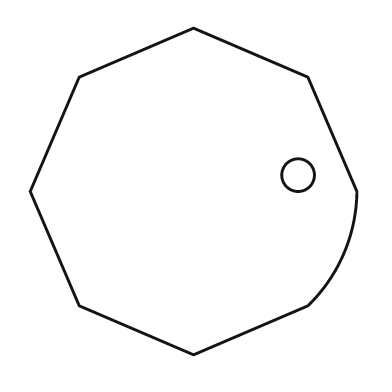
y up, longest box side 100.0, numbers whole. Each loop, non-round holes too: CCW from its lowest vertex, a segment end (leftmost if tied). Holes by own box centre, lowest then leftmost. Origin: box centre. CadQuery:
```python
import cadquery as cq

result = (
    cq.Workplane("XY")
    .moveTo(0.0, -50.0)
    .lineTo(35.0, -35.0)
    .threePointArc((46.0, -19.0), (50.0, 0.0))
    .lineTo(35.0, 35.0)
    .lineTo(0.0, 50.0)
    .lineTo(-35.0, 35.0)
    .lineTo(-50.0, 0.0)
    .lineTo(-35.0, -35.0)
    .close()
    .moveTo(32.0, 5.0)
    .circle(5.0)
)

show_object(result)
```